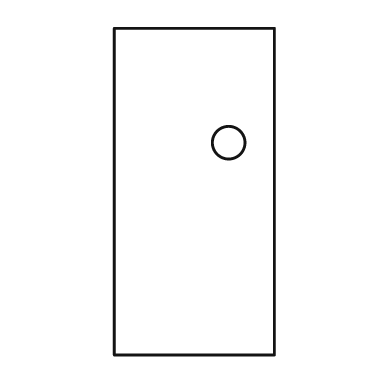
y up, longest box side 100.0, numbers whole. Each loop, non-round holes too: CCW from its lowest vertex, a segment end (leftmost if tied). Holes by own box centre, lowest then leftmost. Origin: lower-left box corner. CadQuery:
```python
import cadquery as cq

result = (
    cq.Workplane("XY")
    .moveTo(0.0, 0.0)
    .lineTo(49.0, 0.0)
    .lineTo(49.0, 100.0)
    .lineTo(0.0, 100.0)
    .close()
    .moveTo(35.0, 65.0)
    .circle(5.0)
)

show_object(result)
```